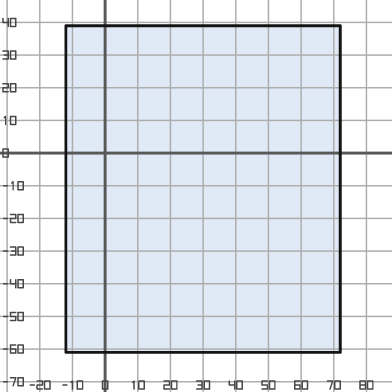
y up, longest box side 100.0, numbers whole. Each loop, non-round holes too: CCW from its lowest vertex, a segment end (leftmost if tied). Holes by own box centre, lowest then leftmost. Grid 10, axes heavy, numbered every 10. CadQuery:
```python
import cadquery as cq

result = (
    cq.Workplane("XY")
    .moveTo(-12.0, -61.0)
    .lineTo(72.0, -61.0)
    .lineTo(72.0, 39.0)
    .lineTo(-12.0, 39.0)
    .close()
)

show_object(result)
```